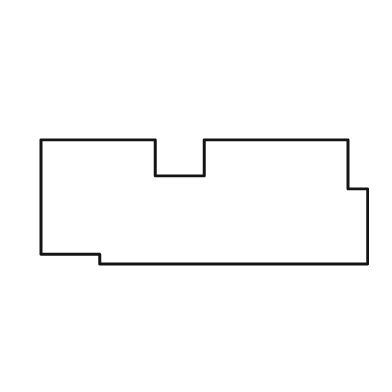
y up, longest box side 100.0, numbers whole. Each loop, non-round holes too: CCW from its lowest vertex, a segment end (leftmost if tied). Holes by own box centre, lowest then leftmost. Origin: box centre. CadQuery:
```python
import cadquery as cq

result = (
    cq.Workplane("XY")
    .moveTo(-32.0, -19.0)
    .lineTo(50.0, -19.0)
    .lineTo(50.0, 4.0)
    .lineTo(44.0, 4.0)
    .lineTo(44.0, 19.0)
    .lineTo(0.0, 19.0)
    .lineTo(0.0, 8.0)
    .lineTo(-15.0, 8.0)
    .lineTo(-15.0, 19.0)
    .lineTo(-50.0, 19.0)
    .lineTo(-50.0, -16.0)
    .lineTo(-32.0, -16.0)
    .close()
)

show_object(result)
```